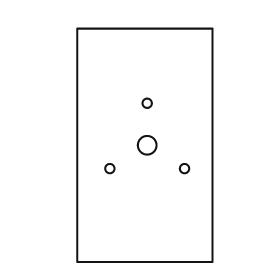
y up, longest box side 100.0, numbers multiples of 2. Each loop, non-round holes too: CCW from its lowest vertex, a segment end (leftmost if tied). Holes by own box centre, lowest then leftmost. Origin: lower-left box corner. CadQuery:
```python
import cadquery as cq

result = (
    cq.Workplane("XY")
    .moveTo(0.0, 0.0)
    .lineTo(58.0, 0.0)
    .lineTo(58.0, 100.0)
    .lineTo(0.0, 100.0)
    .close()
    .moveTo(14.0, 40.0)
    .circle(2.0)
    .moveTo(46.0, 40.0)
    .circle(2.0)
    .moveTo(30.0, 50.0)
    .circle(4.0)
    .moveTo(30.0, 68.0)
    .circle(2.0)
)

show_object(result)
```